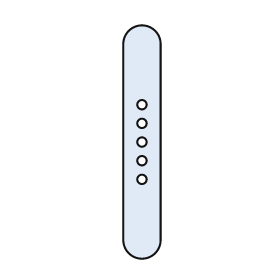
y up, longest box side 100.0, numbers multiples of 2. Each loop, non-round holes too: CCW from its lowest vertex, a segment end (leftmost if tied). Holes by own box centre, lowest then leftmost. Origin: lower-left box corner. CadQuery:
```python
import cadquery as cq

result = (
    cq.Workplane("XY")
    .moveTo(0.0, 8.0)
    .threePointArc((8.0, 0.0), (16.0, 8.0))
    .lineTo(16.0, 92.0)
    .threePointArc((8.0, 100.0), (0.0, 92.0))
    .close()
    .moveTo(8.0, 34.0)
    .circle(2.0)
    .moveTo(8.0, 42.0)
    .circle(2.0)
    .moveTo(8.0, 50.0)
    .circle(2.0)
    .moveTo(8.0, 58.0)
    .circle(2.0)
    .moveTo(8.0, 66.0)
    .circle(2.0)
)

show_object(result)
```